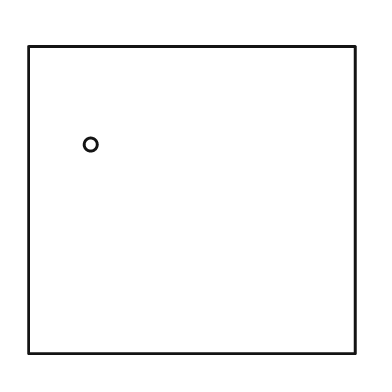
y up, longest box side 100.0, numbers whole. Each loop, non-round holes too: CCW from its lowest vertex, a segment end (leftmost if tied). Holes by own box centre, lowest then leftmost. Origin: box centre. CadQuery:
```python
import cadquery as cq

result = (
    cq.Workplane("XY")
    .moveTo(-50.0, -47.0)
    .lineTo(50.0, -47.0)
    .lineTo(50.0, 47.0)
    .lineTo(-50.0, 47.0)
    .close()
    .moveTo(-31.0, 17.0)
    .circle(2.0)
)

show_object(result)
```